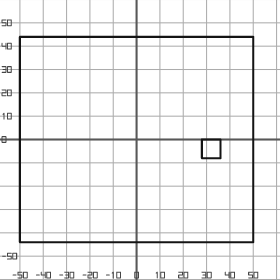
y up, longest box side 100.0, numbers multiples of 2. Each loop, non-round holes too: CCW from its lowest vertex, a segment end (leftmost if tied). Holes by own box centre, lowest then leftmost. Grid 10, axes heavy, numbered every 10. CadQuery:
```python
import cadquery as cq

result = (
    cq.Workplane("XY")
    .moveTo(-50.0, -44.0)
    .lineTo(50.0, -44.0)
    .lineTo(50.0, 44.0)
    .lineTo(-50.0, 44.0)
    .close()
    .moveTo(28.0, -8.0)
    .lineTo(36.0, -8.0)
    .lineTo(36.0, 0.0)
    .lineTo(28.0, 0.0)
    .close()
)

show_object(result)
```